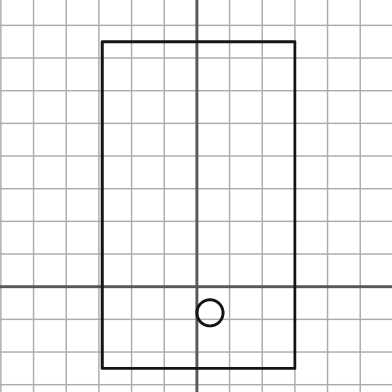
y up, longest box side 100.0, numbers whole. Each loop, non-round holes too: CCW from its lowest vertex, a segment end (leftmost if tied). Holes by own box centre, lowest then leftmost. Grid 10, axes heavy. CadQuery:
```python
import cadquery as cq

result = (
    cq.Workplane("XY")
    .moveTo(-29.0, -25.0)
    .lineTo(30.0, -25.0)
    .lineTo(30.0, 75.0)
    .lineTo(-29.0, 75.0)
    .close()
    .moveTo(4.0, -8.0)
    .circle(4.0)
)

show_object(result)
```